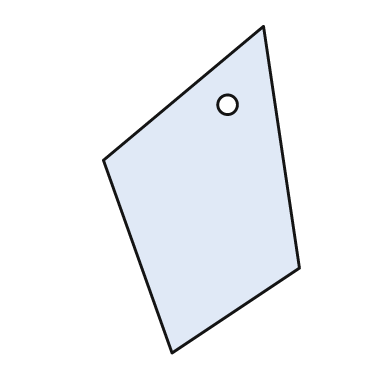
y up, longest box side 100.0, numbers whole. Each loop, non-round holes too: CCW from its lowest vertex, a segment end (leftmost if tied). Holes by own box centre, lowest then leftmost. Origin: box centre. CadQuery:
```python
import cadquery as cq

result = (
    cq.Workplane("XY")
    .moveTo(-9.0, -50.0)
    .lineTo(30.0, -24.0)
    .lineTo(19.0, 50.0)
    .lineTo(-30.0, 9.0)
    .close()
    .moveTo(8.0, 26.0)
    .circle(3.0)
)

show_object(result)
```